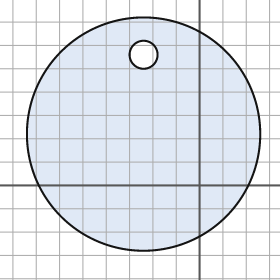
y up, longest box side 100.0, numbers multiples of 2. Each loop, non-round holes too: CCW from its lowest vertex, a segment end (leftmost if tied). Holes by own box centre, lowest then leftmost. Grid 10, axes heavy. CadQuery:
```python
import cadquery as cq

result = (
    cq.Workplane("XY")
    .moveTo(-24.0, 22.0)
    .circle(50.0)
    .moveTo(-24.0, 56.0)
    .circle(6.0)
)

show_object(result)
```